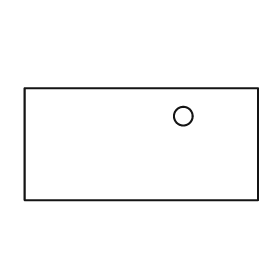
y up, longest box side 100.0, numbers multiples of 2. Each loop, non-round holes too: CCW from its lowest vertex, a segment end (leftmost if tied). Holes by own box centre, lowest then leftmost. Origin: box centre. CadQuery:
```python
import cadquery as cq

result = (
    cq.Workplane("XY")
    .moveTo(-50.0, -24.0)
    .lineTo(50.0, -24.0)
    .lineTo(50.0, 24.0)
    .lineTo(-50.0, 24.0)
    .close()
    .moveTo(18.0, 12.0)
    .circle(4.0)
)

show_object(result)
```